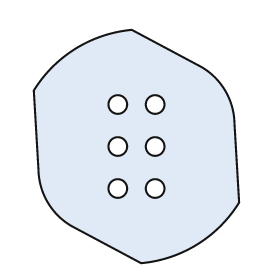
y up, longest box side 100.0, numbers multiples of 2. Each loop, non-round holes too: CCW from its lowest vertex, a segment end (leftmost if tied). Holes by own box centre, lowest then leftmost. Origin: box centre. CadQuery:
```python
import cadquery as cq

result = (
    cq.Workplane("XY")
    .moveTo(2.0, -50.0)
    .threePointArc((26.0, -42.0), (44.0, -24.0))
    .lineTo(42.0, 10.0)
    .threePointArc((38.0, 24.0), (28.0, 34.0))
    .lineTo(-2.0, 50.0)
    .threePointArc((-26.0, 42.0), (-44.0, 24.0))
    .lineTo(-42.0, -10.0)
    .threePointArc((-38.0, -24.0), (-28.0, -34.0))
    .close()
    .moveTo(-8.0, -18.0)
    .circle(4.0)
    .moveTo(8.0, -18.0)
    .circle(4.0)
    .moveTo(-8.0, 0.0)
    .circle(4.0)
    .moveTo(8.0, 0.0)
    .circle(4.0)
    .moveTo(-8.0, 18.0)
    .circle(4.0)
    .moveTo(8.0, 18.0)
    .circle(4.0)
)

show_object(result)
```